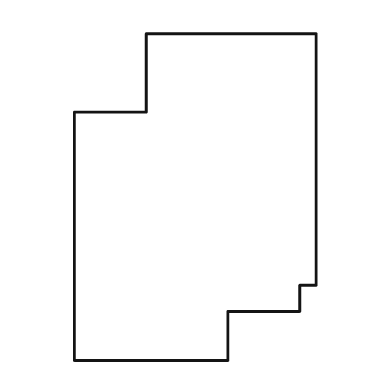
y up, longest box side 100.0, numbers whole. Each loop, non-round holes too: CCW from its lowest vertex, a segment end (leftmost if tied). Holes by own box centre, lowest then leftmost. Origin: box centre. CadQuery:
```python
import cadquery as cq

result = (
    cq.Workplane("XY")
    .moveTo(-37.0, -50.0)
    .lineTo(10.0, -50.0)
    .lineTo(10.0, -35.0)
    .lineTo(32.0, -35.0)
    .lineTo(32.0, -27.0)
    .lineTo(37.0, -27.0)
    .lineTo(37.0, 50.0)
    .lineTo(-15.0, 50.0)
    .lineTo(-15.0, 26.0)
    .lineTo(-37.0, 26.0)
    .close()
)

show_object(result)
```